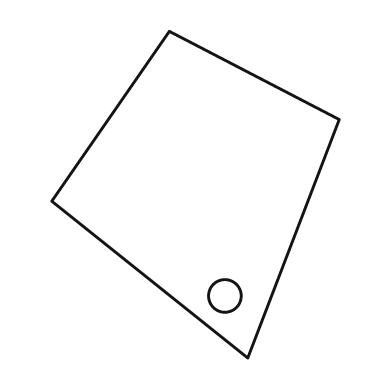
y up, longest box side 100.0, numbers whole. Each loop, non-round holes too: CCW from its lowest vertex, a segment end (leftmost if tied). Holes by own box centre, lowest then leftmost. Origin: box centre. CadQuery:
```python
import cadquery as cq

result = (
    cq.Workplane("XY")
    .moveTo(16.0, -50.0)
    .lineTo(44.0, 23.0)
    .lineTo(-8.0, 50.0)
    .lineTo(-44.0, -2.0)
    .close()
    .moveTo(9.0, -31.0)
    .circle(5.0)
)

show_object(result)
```